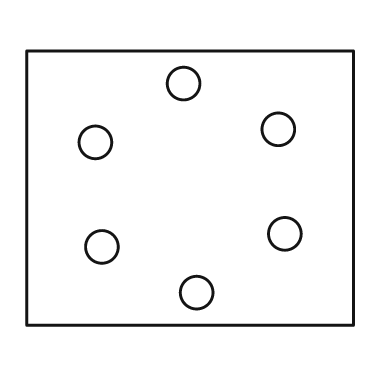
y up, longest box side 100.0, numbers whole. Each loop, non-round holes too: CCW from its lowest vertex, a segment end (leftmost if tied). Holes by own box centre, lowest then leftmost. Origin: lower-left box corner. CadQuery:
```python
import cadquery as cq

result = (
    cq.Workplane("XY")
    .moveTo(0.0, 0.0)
    .lineTo(100.0, 0.0)
    .lineTo(100.0, 84.0)
    .lineTo(0.0, 84.0)
    .close()
    .moveTo(52.0, 10.0)
    .circle(5.0)
    .moveTo(23.0, 24.0)
    .circle(5.0)
    .moveTo(79.0, 28.0)
    .circle(5.0)
    .moveTo(21.0, 56.0)
    .circle(5.0)
    .moveTo(77.0, 60.0)
    .circle(5.0)
    .moveTo(48.0, 74.0)
    .circle(5.0)
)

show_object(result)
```